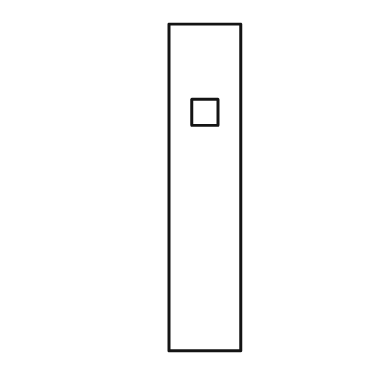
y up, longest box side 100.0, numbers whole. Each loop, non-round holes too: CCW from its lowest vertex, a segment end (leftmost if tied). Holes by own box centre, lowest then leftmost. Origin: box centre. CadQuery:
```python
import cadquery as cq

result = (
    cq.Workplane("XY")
    .moveTo(-11.0, -50.0)
    .lineTo(11.0, -50.0)
    .lineTo(11.0, 50.0)
    .lineTo(-11.0, 50.0)
    .close()
    .moveTo(-4.0, 19.0)
    .lineTo(4.0, 19.0)
    .lineTo(4.0, 27.0)
    .lineTo(-4.0, 27.0)
    .close()
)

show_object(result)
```